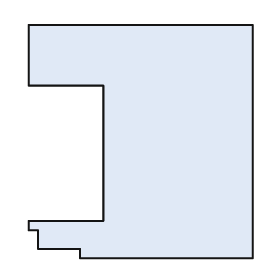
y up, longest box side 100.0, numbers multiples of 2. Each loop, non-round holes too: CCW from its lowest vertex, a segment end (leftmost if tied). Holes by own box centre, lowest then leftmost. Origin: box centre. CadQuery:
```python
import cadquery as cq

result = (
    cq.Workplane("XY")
    .moveTo(-26.0, -50.0)
    .lineTo(48.0, -50.0)
    .lineTo(48.0, 50.0)
    .lineTo(-48.0, 50.0)
    .lineTo(-48.0, 24.0)
    .lineTo(-16.0, 24.0)
    .lineTo(-16.0, -34.0)
    .lineTo(-48.0, -34.0)
    .lineTo(-48.0, -38.0)
    .lineTo(-44.0, -38.0)
    .lineTo(-44.0, -46.0)
    .lineTo(-26.0, -46.0)
    .close()
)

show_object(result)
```